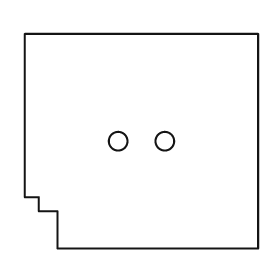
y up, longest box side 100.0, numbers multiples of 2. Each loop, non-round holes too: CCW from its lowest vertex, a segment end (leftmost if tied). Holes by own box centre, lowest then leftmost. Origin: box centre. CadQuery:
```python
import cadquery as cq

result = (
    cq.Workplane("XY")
    .moveTo(-36.0, -46.0)
    .lineTo(50.0, -46.0)
    .lineTo(50.0, 46.0)
    .lineTo(-50.0, 46.0)
    .lineTo(-50.0, -24.0)
    .lineTo(-44.0, -24.0)
    .lineTo(-44.0, -30.0)
    .lineTo(-36.0, -30.0)
    .close()
    .moveTo(-10.0, 0.0)
    .circle(4.0)
    .moveTo(10.0, 0.0)
    .circle(4.0)
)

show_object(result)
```